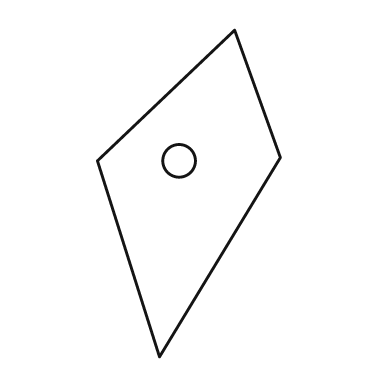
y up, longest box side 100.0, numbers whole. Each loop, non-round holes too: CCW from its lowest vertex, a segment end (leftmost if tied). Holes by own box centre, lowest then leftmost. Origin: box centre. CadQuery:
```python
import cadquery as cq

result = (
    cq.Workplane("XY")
    .moveTo(-9.0, -50.0)
    .lineTo(28.0, 11.0)
    .lineTo(14.0, 50.0)
    .lineTo(-28.0, 10.0)
    .close()
    .moveTo(-3.0, 10.0)
    .circle(5.0)
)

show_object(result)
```